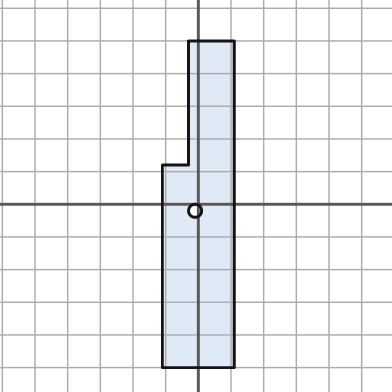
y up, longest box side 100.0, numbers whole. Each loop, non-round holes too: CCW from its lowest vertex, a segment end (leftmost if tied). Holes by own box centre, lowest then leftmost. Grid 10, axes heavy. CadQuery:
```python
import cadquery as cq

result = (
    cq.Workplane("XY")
    .moveTo(-11.0, -50.0)
    .lineTo(11.0, -50.0)
    .lineTo(11.0, 50.0)
    .lineTo(-3.0, 50.0)
    .lineTo(-3.0, 12.0)
    .lineTo(-11.0, 12.0)
    .close()
    .moveTo(-1.0, -2.0)
    .circle(2.0)
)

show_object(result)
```